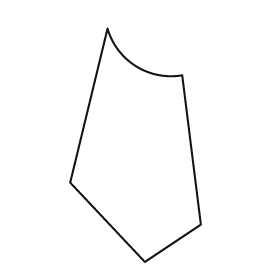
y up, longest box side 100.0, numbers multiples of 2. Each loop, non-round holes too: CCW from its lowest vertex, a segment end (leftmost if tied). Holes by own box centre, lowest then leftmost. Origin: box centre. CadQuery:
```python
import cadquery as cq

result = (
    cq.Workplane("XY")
    .moveTo(4.0, -50.0)
    .lineTo(28.0, -34.0)
    .lineTo(20.0, 30.0)
    .threePointArc((0.0, 34.0), (-12.0, 50.0))
    .lineTo(-28.0, -16.0)
    .close()
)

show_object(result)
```